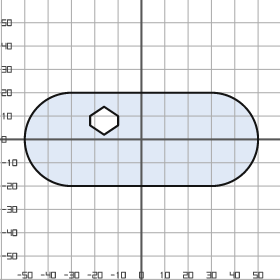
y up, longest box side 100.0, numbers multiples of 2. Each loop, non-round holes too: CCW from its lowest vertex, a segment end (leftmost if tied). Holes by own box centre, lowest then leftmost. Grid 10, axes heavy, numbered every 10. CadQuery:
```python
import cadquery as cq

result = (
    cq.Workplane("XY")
    .moveTo(-30.0, -20.0)
    .lineTo(30.0, -20.0)
    .threePointArc((50.0, 0.0), (30.0, 20.0))
    .lineTo(-30.0, 20.0)
    .threePointArc((-50.0, 0.0), (-30.0, -20.0))
    .close()
    .moveTo(-16.0, 2.0)
    .lineTo(-10.0, 6.0)
    .lineTo(-10.0, 10.0)
    .lineTo(-16.0, 14.0)
    .lineTo(-22.0, 10.0)
    .lineTo(-22.0, 6.0)
    .close()
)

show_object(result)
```